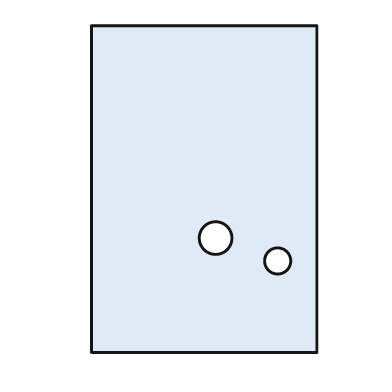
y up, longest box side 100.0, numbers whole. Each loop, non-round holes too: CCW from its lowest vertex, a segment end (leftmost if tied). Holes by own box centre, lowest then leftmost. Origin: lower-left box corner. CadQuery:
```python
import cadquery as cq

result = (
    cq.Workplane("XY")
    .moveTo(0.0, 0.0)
    .lineTo(69.0, 0.0)
    .lineTo(69.0, 100.0)
    .lineTo(0.0, 100.0)
    .close()
    .moveTo(57.0, 28.0)
    .circle(4.0)
    .moveTo(38.0, 35.0)
    .circle(5.0)
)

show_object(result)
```